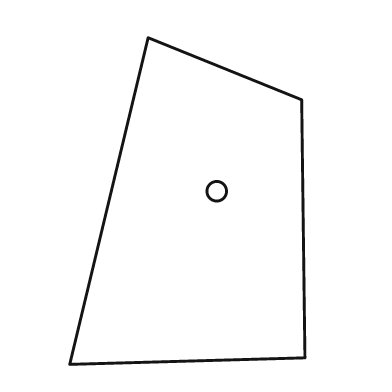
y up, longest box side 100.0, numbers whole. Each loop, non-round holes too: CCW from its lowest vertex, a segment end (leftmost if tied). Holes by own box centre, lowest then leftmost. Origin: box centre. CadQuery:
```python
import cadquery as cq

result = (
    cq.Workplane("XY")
    .moveTo(-36.0, -50.0)
    .lineTo(36.0, -48.0)
    .lineTo(35.0, 31.0)
    .lineTo(-12.0, 50.0)
    .close()
    .moveTo(9.0, 3.0)
    .circle(3.0)
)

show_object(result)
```